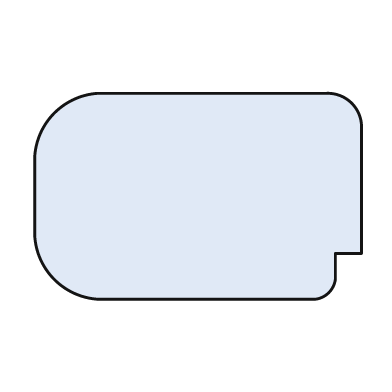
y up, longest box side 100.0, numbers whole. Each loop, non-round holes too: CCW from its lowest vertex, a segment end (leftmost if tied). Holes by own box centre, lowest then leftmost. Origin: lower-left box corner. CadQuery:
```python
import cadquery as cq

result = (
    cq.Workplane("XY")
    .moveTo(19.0, 0.0)
    .lineTo(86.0, 0.0)
    .threePointArc((90.0, 2.0), (92.0, 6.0))
    .lineTo(92.0, 14.0)
    .lineTo(100.0, 14.0)
    .lineTo(100.0, 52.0)
    .threePointArc((97.0, 60.0), (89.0, 63.0))
    .lineTo(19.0, 63.0)
    .threePointArc((6.0, 57.0), (0.0, 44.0))
    .lineTo(0.0, 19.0)
    .threePointArc((6.0, 6.0), (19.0, 0.0))
    .close()
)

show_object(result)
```